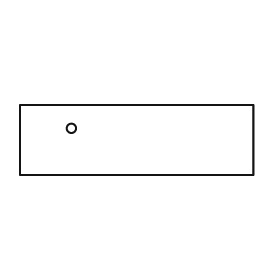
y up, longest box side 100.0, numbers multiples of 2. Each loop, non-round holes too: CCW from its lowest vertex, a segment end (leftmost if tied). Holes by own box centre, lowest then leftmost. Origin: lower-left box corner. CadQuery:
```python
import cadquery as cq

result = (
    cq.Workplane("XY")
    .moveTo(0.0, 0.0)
    .lineTo(100.0, 0.0)
    .lineTo(100.0, 30.0)
    .lineTo(0.0, 30.0)
    .close()
    .moveTo(22.0, 20.0)
    .circle(2.0)
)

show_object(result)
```